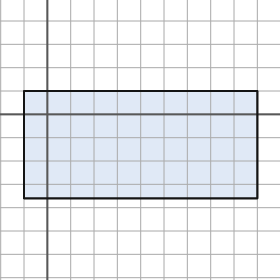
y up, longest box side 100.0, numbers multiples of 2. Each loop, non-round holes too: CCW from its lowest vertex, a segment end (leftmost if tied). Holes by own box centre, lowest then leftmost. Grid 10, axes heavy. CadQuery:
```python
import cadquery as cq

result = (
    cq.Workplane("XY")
    .moveTo(-10.0, -36.0)
    .lineTo(90.0, -36.0)
    .lineTo(90.0, 10.0)
    .lineTo(-10.0, 10.0)
    .close()
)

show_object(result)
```